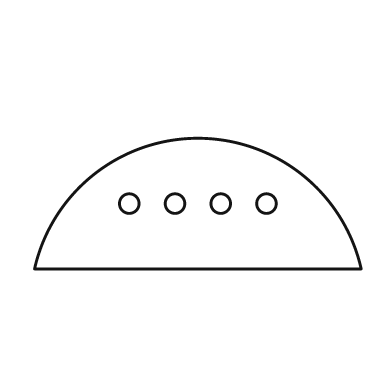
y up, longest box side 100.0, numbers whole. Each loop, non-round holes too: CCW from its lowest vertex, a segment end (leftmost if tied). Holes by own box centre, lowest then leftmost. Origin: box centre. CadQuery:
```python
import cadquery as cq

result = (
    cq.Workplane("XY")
    .moveTo(-50.0, -20.0)
    .lineTo(50.0, -20.0)
    .threePointArc((0.0, 20.0), (-50.0, -20.0))
    .close()
    .moveTo(-21.0, 0.0)
    .circle(3.0)
    .moveTo(-7.0, 0.0)
    .circle(3.0)
    .moveTo(7.0, 0.0)
    .circle(3.0)
    .moveTo(21.0, 0.0)
    .circle(3.0)
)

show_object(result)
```